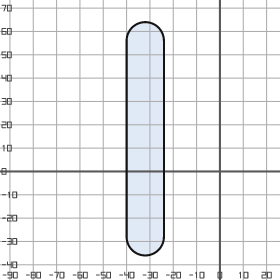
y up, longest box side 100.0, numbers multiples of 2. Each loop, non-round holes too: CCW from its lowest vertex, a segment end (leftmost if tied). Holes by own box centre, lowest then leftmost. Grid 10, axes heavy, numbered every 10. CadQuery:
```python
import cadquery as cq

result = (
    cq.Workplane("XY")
    .moveTo(-40.0, -28.0)
    .threePointArc((-32.0, -36.0), (-24.0, -28.0))
    .lineTo(-24.0, 56.0)
    .threePointArc((-32.0, 64.0), (-40.0, 56.0))
    .close()
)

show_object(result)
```